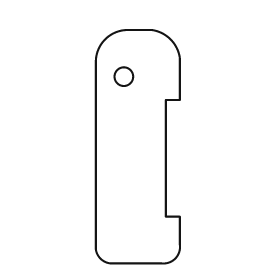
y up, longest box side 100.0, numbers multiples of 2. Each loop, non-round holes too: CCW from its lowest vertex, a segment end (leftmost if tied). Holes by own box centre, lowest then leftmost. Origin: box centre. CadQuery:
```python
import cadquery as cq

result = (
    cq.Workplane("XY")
    .moveTo(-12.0, -50.0)
    .lineTo(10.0, -50.0)
    .threePointArc((16.0, -48.0), (18.0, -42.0))
    .lineTo(18.0, -30.0)
    .lineTo(12.0, -30.0)
    .lineTo(12.0, 20.0)
    .lineTo(18.0, 20.0)
    .lineTo(18.0, 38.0)
    .threePointArc((14.0, 46.0), (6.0, 50.0))
    .lineTo(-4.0, 50.0)
    .threePointArc((-14.0, 46.0), (-18.0, 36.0))
    .lineTo(-18.0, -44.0)
    .threePointArc((-16.0, -48.0), (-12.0, -50.0))
    .close()
    .moveTo(-6.0, 30.0)
    .circle(4.0)
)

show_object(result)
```